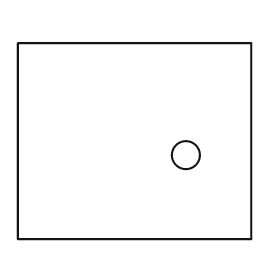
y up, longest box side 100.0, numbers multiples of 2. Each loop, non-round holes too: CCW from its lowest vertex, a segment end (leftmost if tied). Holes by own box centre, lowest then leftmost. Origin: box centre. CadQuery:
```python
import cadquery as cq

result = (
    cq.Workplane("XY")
    .moveTo(-50.0, -42.0)
    .lineTo(50.0, -42.0)
    .lineTo(50.0, 42.0)
    .lineTo(-50.0, 42.0)
    .close()
    .moveTo(22.0, -6.0)
    .circle(6.0)
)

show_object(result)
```